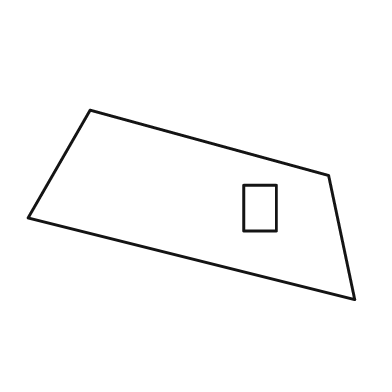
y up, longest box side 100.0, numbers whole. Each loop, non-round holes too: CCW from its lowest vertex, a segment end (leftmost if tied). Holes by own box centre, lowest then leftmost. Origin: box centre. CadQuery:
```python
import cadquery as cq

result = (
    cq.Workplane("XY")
    .moveTo(50.0, -29.0)
    .lineTo(42.0, 9.0)
    .lineTo(-31.0, 29.0)
    .lineTo(-50.0, -4.0)
    .close()
    .moveTo(16.0, -8.0)
    .lineTo(26.0, -8.0)
    .lineTo(26.0, 6.0)
    .lineTo(16.0, 6.0)
    .close()
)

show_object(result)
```